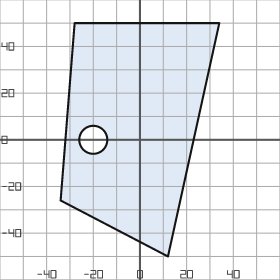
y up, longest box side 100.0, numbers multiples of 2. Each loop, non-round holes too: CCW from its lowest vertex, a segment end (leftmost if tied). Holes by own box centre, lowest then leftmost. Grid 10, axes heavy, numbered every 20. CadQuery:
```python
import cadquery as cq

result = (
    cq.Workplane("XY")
    .moveTo(12.0, -50.0)
    .lineTo(34.0, 50.0)
    .lineTo(-28.0, 50.0)
    .lineTo(-34.0, -26.0)
    .close()
    .moveTo(-20.0, 0.0)
    .circle(6.0)
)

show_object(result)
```